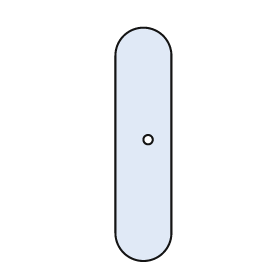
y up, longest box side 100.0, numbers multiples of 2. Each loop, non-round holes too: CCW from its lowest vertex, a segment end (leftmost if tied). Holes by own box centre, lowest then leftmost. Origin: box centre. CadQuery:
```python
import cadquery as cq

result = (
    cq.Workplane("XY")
    .moveTo(-12.0, -38.0)
    .threePointArc((0.0, -50.0), (12.0, -38.0))
    .lineTo(12.0, 38.0)
    .threePointArc((0.0, 50.0), (-12.0, 38.0))
    .close()
    .moveTo(2.0, 2.0)
    .circle(2.0)
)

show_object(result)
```